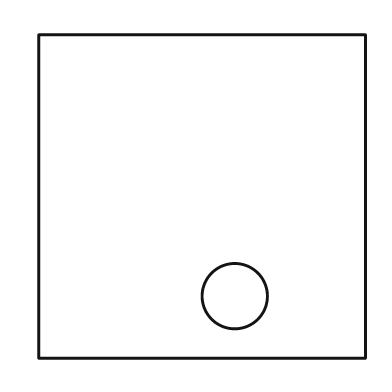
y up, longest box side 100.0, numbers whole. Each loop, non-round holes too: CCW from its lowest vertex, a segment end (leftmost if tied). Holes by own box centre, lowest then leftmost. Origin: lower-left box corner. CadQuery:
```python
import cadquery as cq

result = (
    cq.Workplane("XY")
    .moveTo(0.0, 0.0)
    .lineTo(100.0, 0.0)
    .lineTo(100.0, 99.0)
    .lineTo(0.0, 99.0)
    .close()
    .moveTo(60.0, 19.0)
    .circle(10.0)
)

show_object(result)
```